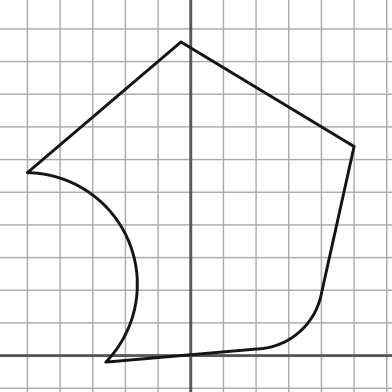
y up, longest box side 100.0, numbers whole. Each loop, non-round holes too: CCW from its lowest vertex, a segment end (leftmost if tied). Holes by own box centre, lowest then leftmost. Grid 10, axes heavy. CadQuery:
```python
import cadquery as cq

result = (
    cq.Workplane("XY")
    .moveTo(-26.0, -2.0)
    .lineTo(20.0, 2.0)
    .threePointArc((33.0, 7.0), (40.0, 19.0))
    .lineTo(50.0, 64.0)
    .lineTo(-3.0, 96.0)
    .lineTo(-50.0, 56.0)
    .threePointArc((-19.0, 35.0), (-26.0, -2.0))
    .close()
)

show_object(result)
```